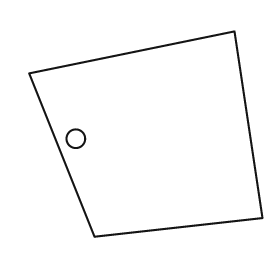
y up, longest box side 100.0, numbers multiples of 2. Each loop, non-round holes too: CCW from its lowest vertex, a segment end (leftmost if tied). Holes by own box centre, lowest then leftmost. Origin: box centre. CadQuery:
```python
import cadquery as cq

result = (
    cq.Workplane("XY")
    .moveTo(-22.0, -44.0)
    .lineTo(50.0, -36.0)
    .lineTo(38.0, 44.0)
    .lineTo(-50.0, 26.0)
    .close()
    .moveTo(-30.0, -2.0)
    .circle(4.0)
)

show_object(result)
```